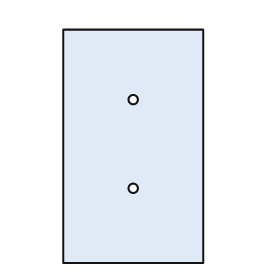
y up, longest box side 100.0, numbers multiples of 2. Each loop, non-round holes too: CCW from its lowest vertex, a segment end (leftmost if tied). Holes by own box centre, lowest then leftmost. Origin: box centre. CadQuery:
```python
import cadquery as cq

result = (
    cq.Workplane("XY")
    .moveTo(-30.0, -50.0)
    .lineTo(30.0, -50.0)
    .lineTo(30.0, 50.0)
    .lineTo(-30.0, 50.0)
    .close()
    .moveTo(0.0, -18.0)
    .circle(2.0)
    .moveTo(0.0, 20.0)
    .circle(2.0)
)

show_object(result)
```